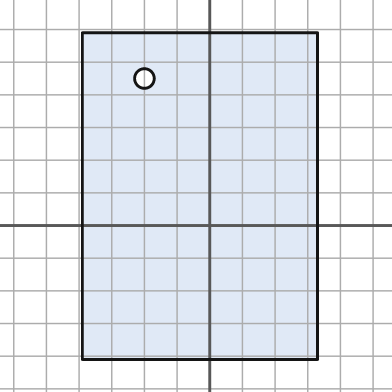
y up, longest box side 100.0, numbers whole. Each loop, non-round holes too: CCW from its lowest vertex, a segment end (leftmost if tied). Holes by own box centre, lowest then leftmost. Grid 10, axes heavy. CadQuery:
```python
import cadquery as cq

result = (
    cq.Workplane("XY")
    .moveTo(-39.0, -41.0)
    .lineTo(33.0, -41.0)
    .lineTo(33.0, 59.0)
    .lineTo(-39.0, 59.0)
    .close()
    .moveTo(-20.0, 45.0)
    .circle(3.0)
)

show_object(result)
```